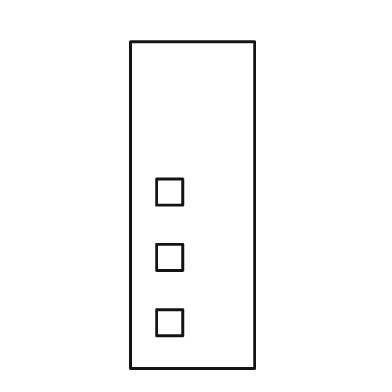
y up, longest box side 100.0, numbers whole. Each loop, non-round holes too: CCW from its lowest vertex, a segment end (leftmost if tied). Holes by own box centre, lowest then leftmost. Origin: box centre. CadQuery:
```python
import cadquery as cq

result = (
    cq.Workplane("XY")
    .moveTo(-19.0, -50.0)
    .lineTo(19.0, -50.0)
    .lineTo(19.0, 50.0)
    .lineTo(-19.0, 50.0)
    .close()
    .moveTo(-11.0, -40.0)
    .lineTo(-3.0, -40.0)
    .lineTo(-3.0, -32.0)
    .lineTo(-11.0, -32.0)
    .close()
    .moveTo(-11.0, -20.0)
    .lineTo(-3.0, -20.0)
    .lineTo(-3.0, -12.0)
    .lineTo(-11.0, -12.0)
    .close()
    .moveTo(-11.0, 0.0)
    .lineTo(-3.0, 0.0)
    .lineTo(-3.0, 8.0)
    .lineTo(-11.0, 8.0)
    .close()
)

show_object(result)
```